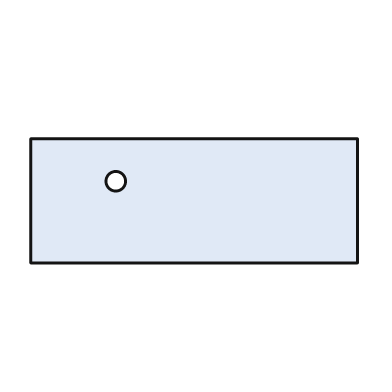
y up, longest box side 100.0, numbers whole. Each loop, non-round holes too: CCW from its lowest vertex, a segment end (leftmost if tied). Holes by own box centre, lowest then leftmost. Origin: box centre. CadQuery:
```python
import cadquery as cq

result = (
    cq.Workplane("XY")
    .moveTo(-50.0, -19.0)
    .lineTo(50.0, -19.0)
    .lineTo(50.0, 19.0)
    .lineTo(-50.0, 19.0)
    .close()
    .moveTo(-24.0, 6.0)
    .circle(3.0)
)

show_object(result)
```